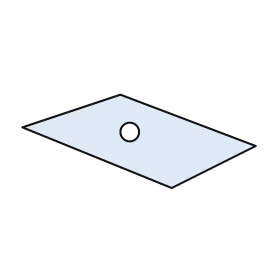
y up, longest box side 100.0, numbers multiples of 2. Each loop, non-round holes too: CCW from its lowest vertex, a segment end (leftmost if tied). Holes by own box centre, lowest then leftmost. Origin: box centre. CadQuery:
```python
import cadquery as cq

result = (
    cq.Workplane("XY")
    .moveTo(14.0, -20.0)
    .lineTo(50.0, -2.0)
    .lineTo(-8.0, 20.0)
    .lineTo(-50.0, 6.0)
    .close()
    .moveTo(-4.0, 4.0)
    .circle(4.0)
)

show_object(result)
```